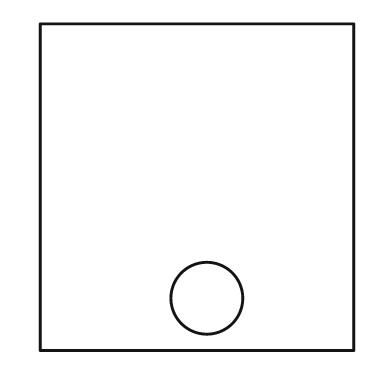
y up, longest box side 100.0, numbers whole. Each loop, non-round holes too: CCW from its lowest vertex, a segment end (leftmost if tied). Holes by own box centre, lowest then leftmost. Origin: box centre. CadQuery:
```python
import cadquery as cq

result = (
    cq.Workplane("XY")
    .moveTo(-48.0, -50.0)
    .lineTo(48.0, -50.0)
    .lineTo(48.0, 50.0)
    .lineTo(-48.0, 50.0)
    .close()
    .moveTo(3.0, -34.0)
    .circle(11.0)
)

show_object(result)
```